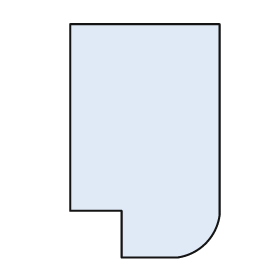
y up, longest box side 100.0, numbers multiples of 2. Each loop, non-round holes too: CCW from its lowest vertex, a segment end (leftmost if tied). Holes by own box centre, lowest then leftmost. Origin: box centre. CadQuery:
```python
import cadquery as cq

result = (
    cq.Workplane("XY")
    .moveTo(-10.0, -50.0)
    .lineTo(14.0, -50.0)
    .threePointArc((26.0, -44.0), (32.0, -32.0))
    .lineTo(32.0, 50.0)
    .lineTo(-32.0, 50.0)
    .lineTo(-32.0, -30.0)
    .lineTo(-10.0, -30.0)
    .close()
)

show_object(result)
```